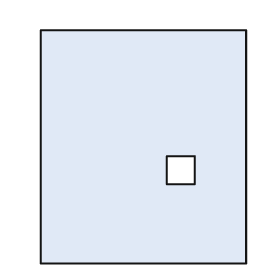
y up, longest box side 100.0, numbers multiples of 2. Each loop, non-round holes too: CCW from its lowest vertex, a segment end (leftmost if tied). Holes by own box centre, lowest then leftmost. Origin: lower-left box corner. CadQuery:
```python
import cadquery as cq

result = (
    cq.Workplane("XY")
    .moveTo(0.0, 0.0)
    .lineTo(88.0, 0.0)
    .lineTo(88.0, 100.0)
    .lineTo(0.0, 100.0)
    .close()
    .moveTo(54.0, 34.0)
    .lineTo(66.0, 34.0)
    .lineTo(66.0, 46.0)
    .lineTo(54.0, 46.0)
    .close()
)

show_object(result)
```